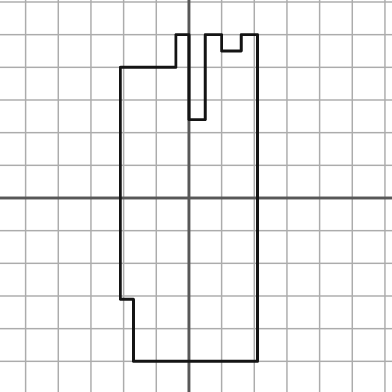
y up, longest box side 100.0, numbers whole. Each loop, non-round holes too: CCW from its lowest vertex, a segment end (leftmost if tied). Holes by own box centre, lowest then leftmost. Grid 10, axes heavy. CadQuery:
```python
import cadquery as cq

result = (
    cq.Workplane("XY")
    .moveTo(-17.0, -50.0)
    .lineTo(21.0, -50.0)
    .lineTo(21.0, 50.0)
    .lineTo(16.0, 50.0)
    .lineTo(16.0, 45.0)
    .lineTo(10.0, 45.0)
    .lineTo(10.0, 50.0)
    .lineTo(5.0, 50.0)
    .lineTo(5.0, 24.0)
    .lineTo(0.0, 24.0)
    .lineTo(0.0, 50.0)
    .lineTo(-4.0, 50.0)
    .lineTo(-4.0, 40.0)
    .lineTo(-21.0, 40.0)
    .lineTo(-21.0, -31.0)
    .lineTo(-17.0, -31.0)
    .close()
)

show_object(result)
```